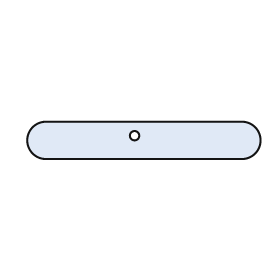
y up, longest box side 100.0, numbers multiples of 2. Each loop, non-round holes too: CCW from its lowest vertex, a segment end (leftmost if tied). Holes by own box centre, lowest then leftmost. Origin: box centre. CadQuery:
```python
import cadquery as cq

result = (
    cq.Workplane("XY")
    .moveTo(-42.0, -8.0)
    .lineTo(42.0, -8.0)
    .threePointArc((50.0, 0.0), (42.0, 8.0))
    .lineTo(-42.0, 8.0)
    .threePointArc((-50.0, 0.0), (-42.0, -8.0))
    .close()
    .moveTo(-4.0, 2.0)
    .circle(2.0)
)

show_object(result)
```